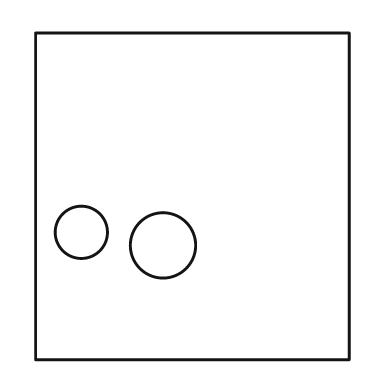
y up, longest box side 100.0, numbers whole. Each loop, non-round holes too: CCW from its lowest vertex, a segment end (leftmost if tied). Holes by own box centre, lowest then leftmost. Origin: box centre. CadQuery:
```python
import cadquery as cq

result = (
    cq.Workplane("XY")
    .moveTo(-48.0, -50.0)
    .lineTo(48.0, -50.0)
    .lineTo(48.0, 50.0)
    .lineTo(-48.0, 50.0)
    .close()
    .moveTo(-9.0, -15.0)
    .circle(10.0)
    .moveTo(-34.0, -11.0)
    .circle(8.0)
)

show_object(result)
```